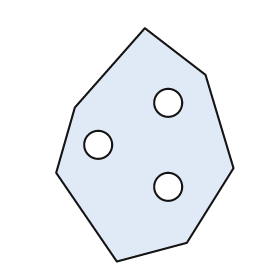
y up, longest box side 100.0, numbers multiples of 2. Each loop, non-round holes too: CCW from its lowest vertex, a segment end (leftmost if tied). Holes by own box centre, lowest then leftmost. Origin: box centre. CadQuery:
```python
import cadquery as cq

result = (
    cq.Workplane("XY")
    .moveTo(-12.0, -50.0)
    .lineTo(18.0, -42.0)
    .lineTo(38.0, -10.0)
    .lineTo(26.0, 30.0)
    .lineTo(0.0, 50.0)
    .lineTo(-30.0, 16.0)
    .lineTo(-38.0, -12.0)
    .close()
    .moveTo(10.0, -18.0)
    .circle(6.0)
    .moveTo(-20.0, 0.0)
    .circle(6.0)
    .moveTo(10.0, 18.0)
    .circle(6.0)
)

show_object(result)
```